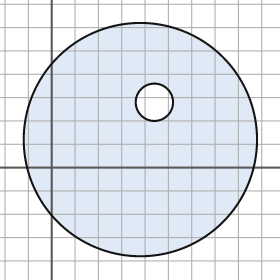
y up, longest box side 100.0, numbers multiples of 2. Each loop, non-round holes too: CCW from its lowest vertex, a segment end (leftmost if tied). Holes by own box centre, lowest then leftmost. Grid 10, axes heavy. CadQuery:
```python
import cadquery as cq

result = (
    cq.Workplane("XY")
    .moveTo(38.0, 12.0)
    .circle(50.0)
    .moveTo(44.0, 28.0)
    .circle(8.0)
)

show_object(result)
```